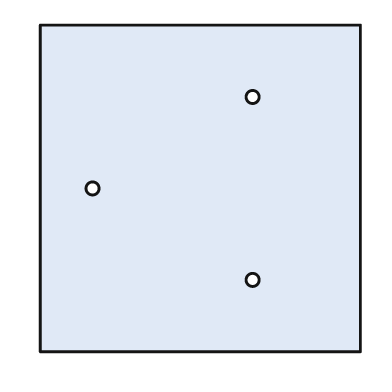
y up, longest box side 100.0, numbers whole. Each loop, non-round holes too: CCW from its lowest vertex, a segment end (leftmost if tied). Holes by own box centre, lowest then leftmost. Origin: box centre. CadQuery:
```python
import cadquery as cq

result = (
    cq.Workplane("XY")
    .moveTo(-49.0, -50.0)
    .lineTo(49.0, -50.0)
    .lineTo(49.0, 50.0)
    .lineTo(-49.0, 50.0)
    .close()
    .moveTo(16.0, -28.0)
    .circle(2.0)
    .moveTo(-33.0, 0.0)
    .circle(2.0)
    .moveTo(16.0, 28.0)
    .circle(2.0)
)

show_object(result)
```